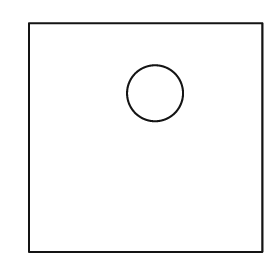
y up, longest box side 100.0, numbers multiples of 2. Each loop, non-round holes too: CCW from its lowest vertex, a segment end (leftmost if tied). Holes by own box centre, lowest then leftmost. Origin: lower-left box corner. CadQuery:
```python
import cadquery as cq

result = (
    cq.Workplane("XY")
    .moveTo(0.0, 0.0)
    .lineTo(100.0, 0.0)
    .lineTo(100.0, 98.0)
    .lineTo(0.0, 98.0)
    .close()
    .moveTo(54.0, 68.0)
    .circle(12.0)
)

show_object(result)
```